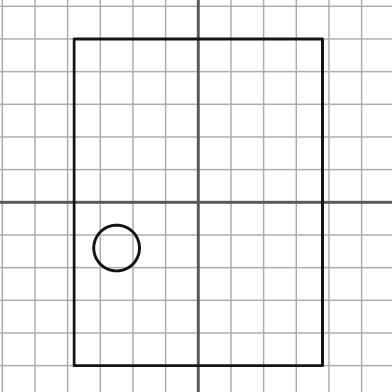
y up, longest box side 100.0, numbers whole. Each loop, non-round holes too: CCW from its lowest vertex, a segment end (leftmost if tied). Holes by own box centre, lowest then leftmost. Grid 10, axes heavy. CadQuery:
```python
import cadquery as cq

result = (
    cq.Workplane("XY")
    .moveTo(-38.0, -50.0)
    .lineTo(38.0, -50.0)
    .lineTo(38.0, 50.0)
    .lineTo(-38.0, 50.0)
    .close()
    .moveTo(-25.0, -14.0)
    .circle(7.0)
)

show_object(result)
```